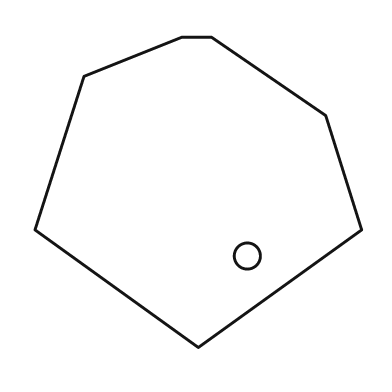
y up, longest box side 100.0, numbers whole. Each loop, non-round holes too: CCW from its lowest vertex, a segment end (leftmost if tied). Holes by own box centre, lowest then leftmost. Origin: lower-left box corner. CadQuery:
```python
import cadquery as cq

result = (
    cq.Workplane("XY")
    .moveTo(50.0, 0.0)
    .lineTo(100.0, 36.0)
    .lineTo(89.0, 71.0)
    .lineTo(54.0, 95.0)
    .lineTo(45.0, 95.0)
    .lineTo(15.0, 83.0)
    .lineTo(0.0, 36.0)
    .close()
    .moveTo(65.0, 28.0)
    .circle(4.0)
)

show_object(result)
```